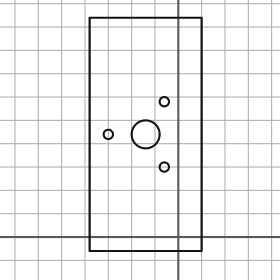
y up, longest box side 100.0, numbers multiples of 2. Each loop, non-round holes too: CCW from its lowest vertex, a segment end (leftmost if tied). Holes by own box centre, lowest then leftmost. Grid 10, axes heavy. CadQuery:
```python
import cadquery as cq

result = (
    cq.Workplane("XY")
    .moveTo(-38.0, -6.0)
    .lineTo(10.0, -6.0)
    .lineTo(10.0, 94.0)
    .lineTo(-38.0, 94.0)
    .close()
    .moveTo(-6.0, 30.0)
    .circle(2.0)
    .moveTo(-30.0, 44.0)
    .circle(2.0)
    .moveTo(-14.0, 44.0)
    .circle(6.0)
    .moveTo(-6.0, 58.0)
    .circle(2.0)
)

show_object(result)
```